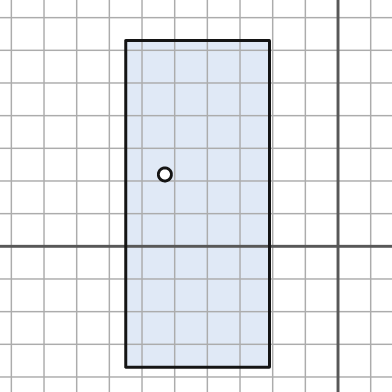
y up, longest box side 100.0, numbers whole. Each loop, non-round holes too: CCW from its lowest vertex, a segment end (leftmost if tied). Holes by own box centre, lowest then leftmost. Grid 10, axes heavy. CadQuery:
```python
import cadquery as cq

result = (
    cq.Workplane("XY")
    .moveTo(-65.0, -37.0)
    .lineTo(-21.0, -37.0)
    .lineTo(-21.0, 63.0)
    .lineTo(-65.0, 63.0)
    .close()
    .moveTo(-53.0, 22.0)
    .circle(2.0)
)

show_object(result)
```